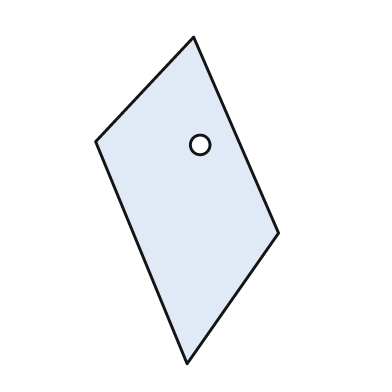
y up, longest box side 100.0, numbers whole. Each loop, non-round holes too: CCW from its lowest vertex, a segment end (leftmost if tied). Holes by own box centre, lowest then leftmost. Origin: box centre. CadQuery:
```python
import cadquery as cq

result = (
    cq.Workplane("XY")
    .moveTo(0.0, -50.0)
    .lineTo(28.0, -10.0)
    .lineTo(2.0, 50.0)
    .lineTo(-28.0, 18.0)
    .close()
    .moveTo(4.0, 17.0)
    .circle(3.0)
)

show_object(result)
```